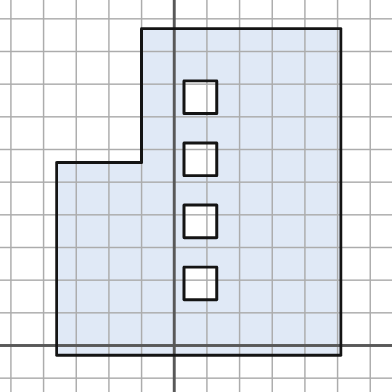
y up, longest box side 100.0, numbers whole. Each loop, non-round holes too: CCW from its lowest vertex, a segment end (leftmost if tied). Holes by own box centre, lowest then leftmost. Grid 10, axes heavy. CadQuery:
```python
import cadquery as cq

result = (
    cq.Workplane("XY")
    .moveTo(-36.0, -3.0)
    .lineTo(51.0, -3.0)
    .lineTo(51.0, 97.0)
    .lineTo(-10.0, 97.0)
    .lineTo(-10.0, 56.0)
    .lineTo(-36.0, 56.0)
    .close()
    .moveTo(3.0, 14.0)
    .lineTo(13.0, 14.0)
    .lineTo(13.0, 24.0)
    .lineTo(3.0, 24.0)
    .close()
    .moveTo(3.0, 33.0)
    .lineTo(13.0, 33.0)
    .lineTo(13.0, 43.0)
    .lineTo(3.0, 43.0)
    .close()
    .moveTo(3.0, 52.0)
    .lineTo(13.0, 52.0)
    .lineTo(13.0, 62.0)
    .lineTo(3.0, 62.0)
    .close()
    .moveTo(3.0, 71.0)
    .lineTo(13.0, 71.0)
    .lineTo(13.0, 81.0)
    .lineTo(3.0, 81.0)
    .close()
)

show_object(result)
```